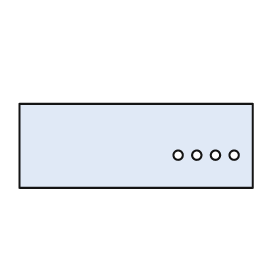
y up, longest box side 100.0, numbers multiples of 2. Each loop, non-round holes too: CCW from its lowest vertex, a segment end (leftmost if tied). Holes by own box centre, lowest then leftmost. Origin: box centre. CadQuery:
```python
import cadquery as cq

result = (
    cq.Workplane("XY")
    .moveTo(-50.0, -18.0)
    .lineTo(50.0, -18.0)
    .lineTo(50.0, 18.0)
    .lineTo(-50.0, 18.0)
    .close()
    .moveTo(18.0, -4.0)
    .circle(2.0)
    .moveTo(26.0, -4.0)
    .circle(2.0)
    .moveTo(34.0, -4.0)
    .circle(2.0)
    .moveTo(42.0, -4.0)
    .circle(2.0)
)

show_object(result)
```